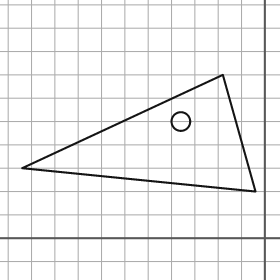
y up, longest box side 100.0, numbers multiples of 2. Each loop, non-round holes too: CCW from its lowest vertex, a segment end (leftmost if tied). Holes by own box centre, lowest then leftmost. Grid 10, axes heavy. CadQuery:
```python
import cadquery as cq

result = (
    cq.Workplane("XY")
    .moveTo(-4.0, 20.0)
    .lineTo(-18.0, 70.0)
    .lineTo(-104.0, 30.0)
    .close()
    .moveTo(-36.0, 50.0)
    .circle(4.0)
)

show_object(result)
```